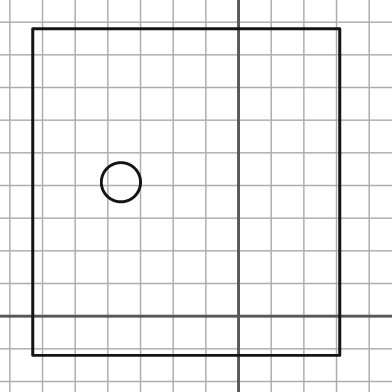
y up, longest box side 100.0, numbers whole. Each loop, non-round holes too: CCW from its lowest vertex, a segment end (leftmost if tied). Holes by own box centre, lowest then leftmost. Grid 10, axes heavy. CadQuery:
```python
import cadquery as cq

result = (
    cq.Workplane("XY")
    .moveTo(-63.0, -12.0)
    .lineTo(31.0, -12.0)
    .lineTo(31.0, 88.0)
    .lineTo(-63.0, 88.0)
    .close()
    .moveTo(-36.0, 41.0)
    .circle(6.0)
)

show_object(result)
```